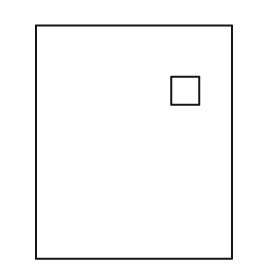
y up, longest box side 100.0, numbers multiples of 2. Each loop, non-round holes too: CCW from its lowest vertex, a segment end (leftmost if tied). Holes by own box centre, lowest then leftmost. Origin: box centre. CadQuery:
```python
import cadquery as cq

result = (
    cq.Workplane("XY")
    .moveTo(-42.0, -50.0)
    .lineTo(42.0, -50.0)
    .lineTo(42.0, 50.0)
    .lineTo(-42.0, 50.0)
    .close()
    .moveTo(16.0, 16.0)
    .lineTo(28.0, 16.0)
    .lineTo(28.0, 28.0)
    .lineTo(16.0, 28.0)
    .close()
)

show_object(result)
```